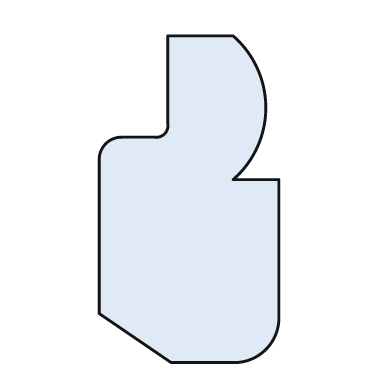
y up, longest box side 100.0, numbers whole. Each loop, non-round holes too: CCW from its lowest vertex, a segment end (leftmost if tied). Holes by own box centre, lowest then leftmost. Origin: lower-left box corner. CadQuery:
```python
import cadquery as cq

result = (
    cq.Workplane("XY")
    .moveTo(22.0, 0.0)
    .lineTo(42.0, 0.0)
    .threePointArc((51.0, 4.0), (55.0, 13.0))
    .lineTo(55.0, 56.0)
    .lineTo(41.0, 56.0)
    .threePointArc((51.0, 78.0), (41.0, 100.0))
    .lineTo(21.0, 100.0)
    .lineTo(21.0, 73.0)
    .threePointArc((20.0, 70.0), (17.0, 69.0))
    .lineTo(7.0, 69.0)
    .threePointArc((2.0, 67.0), (0.0, 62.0))
    .lineTo(0.0, 15.0)
    .close()
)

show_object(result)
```